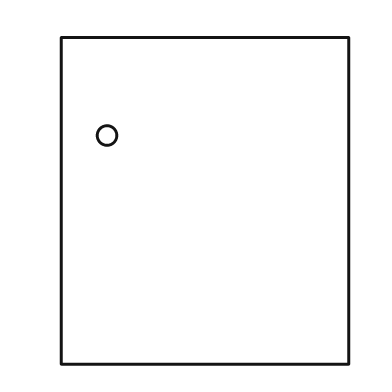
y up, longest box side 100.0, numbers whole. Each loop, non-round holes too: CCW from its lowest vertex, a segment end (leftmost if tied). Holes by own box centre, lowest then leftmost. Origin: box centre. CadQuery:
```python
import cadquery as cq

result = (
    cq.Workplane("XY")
    .moveTo(-44.0, -50.0)
    .lineTo(44.0, -50.0)
    .lineTo(44.0, 50.0)
    .lineTo(-44.0, 50.0)
    .close()
    .moveTo(-30.0, 20.0)
    .circle(3.0)
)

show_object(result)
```